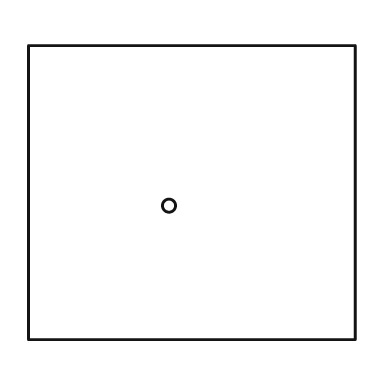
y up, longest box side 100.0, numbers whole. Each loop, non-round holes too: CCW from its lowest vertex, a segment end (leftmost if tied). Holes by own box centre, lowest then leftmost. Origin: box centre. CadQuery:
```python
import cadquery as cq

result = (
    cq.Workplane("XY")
    .moveTo(-50.0, -45.0)
    .lineTo(50.0, -45.0)
    .lineTo(50.0, 45.0)
    .lineTo(-50.0, 45.0)
    .close()
    .moveTo(-7.0, -4.0)
    .circle(2.0)
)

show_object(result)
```